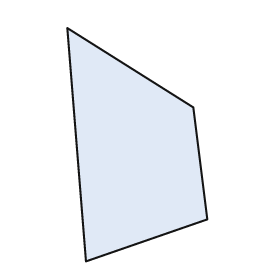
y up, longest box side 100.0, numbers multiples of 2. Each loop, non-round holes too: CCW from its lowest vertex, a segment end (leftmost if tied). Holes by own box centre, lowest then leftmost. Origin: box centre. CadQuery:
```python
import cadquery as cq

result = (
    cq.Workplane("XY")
    .moveTo(-22.0, -50.0)
    .lineTo(30.0, -32.0)
    .lineTo(24.0, 16.0)
    .lineTo(-30.0, 50.0)
    .close()
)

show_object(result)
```